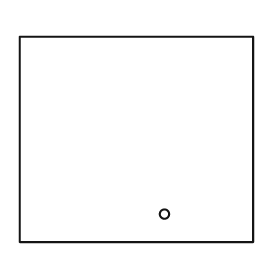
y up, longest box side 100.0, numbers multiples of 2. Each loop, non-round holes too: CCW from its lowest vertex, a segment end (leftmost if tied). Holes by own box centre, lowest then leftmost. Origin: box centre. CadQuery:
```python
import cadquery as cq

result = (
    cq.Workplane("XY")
    .moveTo(-50.0, -44.0)
    .lineTo(50.0, -44.0)
    .lineTo(50.0, 44.0)
    .lineTo(-50.0, 44.0)
    .close()
    .moveTo(12.0, -32.0)
    .circle(2.0)
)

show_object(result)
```